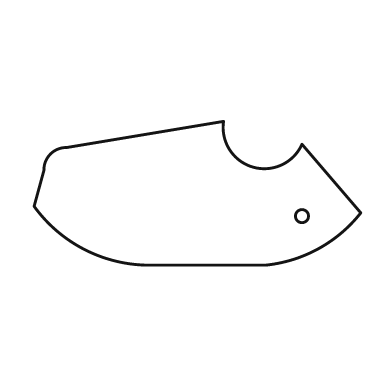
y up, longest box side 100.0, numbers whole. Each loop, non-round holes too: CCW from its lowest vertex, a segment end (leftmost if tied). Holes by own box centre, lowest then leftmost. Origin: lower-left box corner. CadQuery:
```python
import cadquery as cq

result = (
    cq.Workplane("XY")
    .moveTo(34.0, 0.0)
    .lineTo(71.0, 0.0)
    .threePointArc((87.0, 5.0), (100.0, 16.0))
    .lineTo(82.0, 37.0)
    .threePointArc((67.0, 30.0), (58.0, 44.0))
    .lineTo(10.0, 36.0)
    .threePointArc((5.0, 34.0), (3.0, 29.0))
    .lineTo(0.0, 18.0)
    .threePointArc((15.0, 5.0), (34.0, 0.0))
    .close()
    .moveTo(82.0, 15.0)
    .circle(2.0)
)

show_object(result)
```